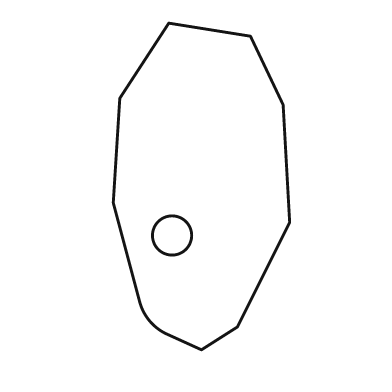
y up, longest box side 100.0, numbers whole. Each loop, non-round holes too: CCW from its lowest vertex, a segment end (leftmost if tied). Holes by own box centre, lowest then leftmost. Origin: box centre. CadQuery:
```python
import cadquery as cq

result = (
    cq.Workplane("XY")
    .moveTo(0.0, -50.0)
    .lineTo(11.0, -43.0)
    .lineTo(27.0, -11.0)
    .lineTo(25.0, 25.0)
    .lineTo(15.0, 46.0)
    .lineTo(-10.0, 50.0)
    .lineTo(-25.0, 27.0)
    .lineTo(-27.0, -5.0)
    .lineTo(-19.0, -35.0)
    .threePointArc((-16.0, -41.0), (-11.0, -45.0))
    .close()
    .moveTo(-9.0, -15.0)
    .circle(6.0)
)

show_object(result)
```